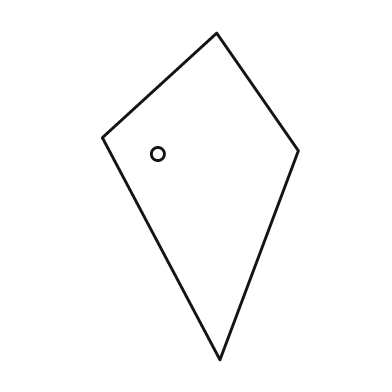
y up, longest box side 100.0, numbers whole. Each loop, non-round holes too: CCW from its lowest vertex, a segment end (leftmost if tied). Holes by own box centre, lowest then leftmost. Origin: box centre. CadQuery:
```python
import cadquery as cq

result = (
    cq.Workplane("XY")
    .moveTo(6.0, -50.0)
    .lineTo(30.0, 14.0)
    .lineTo(5.0, 50.0)
    .lineTo(-30.0, 18.0)
    .close()
    .moveTo(-13.0, 13.0)
    .circle(2.0)
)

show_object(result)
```